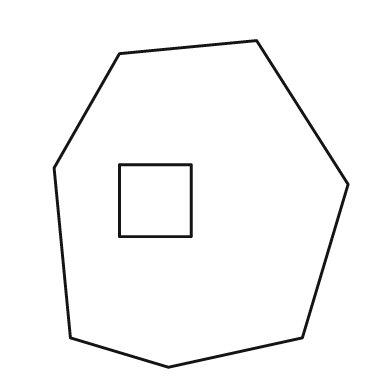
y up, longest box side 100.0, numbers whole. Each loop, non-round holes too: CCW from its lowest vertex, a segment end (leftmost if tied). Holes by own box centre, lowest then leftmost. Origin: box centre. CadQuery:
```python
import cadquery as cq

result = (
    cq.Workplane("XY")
    .moveTo(-10.0, -50.0)
    .lineTo(31.0, -41.0)
    .lineTo(45.0, 6.0)
    .lineTo(17.0, 50.0)
    .lineTo(-25.0, 46.0)
    .lineTo(-45.0, 11.0)
    .lineTo(-40.0, -41.0)
    .close()
    .moveTo(-25.0, -10.0)
    .lineTo(-3.0, -10.0)
    .lineTo(-3.0, 12.0)
    .lineTo(-25.0, 12.0)
    .close()
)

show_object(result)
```